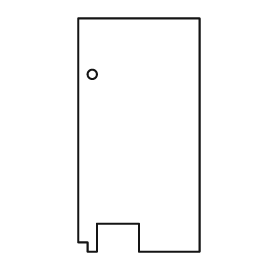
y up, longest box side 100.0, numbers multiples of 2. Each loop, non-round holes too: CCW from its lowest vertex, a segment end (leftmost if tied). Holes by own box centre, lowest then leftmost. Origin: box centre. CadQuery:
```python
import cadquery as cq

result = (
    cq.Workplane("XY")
    .moveTo(-22.0, -50.0)
    .lineTo(-18.0, -50.0)
    .lineTo(-18.0, -38.0)
    .lineTo(0.0, -38.0)
    .lineTo(0.0, -50.0)
    .lineTo(26.0, -50.0)
    .lineTo(26.0, 50.0)
    .lineTo(-26.0, 50.0)
    .lineTo(-26.0, -46.0)
    .lineTo(-22.0, -46.0)
    .close()
    .moveTo(-20.0, 26.0)
    .circle(2.0)
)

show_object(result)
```